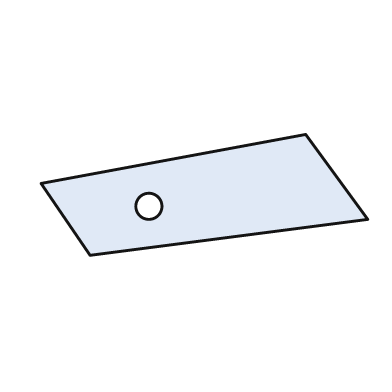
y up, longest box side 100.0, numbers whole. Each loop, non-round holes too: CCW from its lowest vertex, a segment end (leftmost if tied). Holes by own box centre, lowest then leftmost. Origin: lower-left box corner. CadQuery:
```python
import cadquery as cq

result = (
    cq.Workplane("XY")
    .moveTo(15.0, 0.0)
    .lineTo(100.0, 11.0)
    .lineTo(81.0, 37.0)
    .lineTo(0.0, 22.0)
    .close()
    .moveTo(33.0, 15.0)
    .circle(4.0)
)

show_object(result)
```